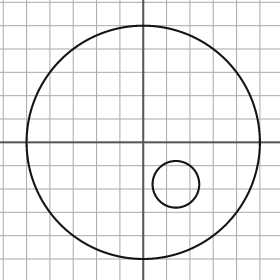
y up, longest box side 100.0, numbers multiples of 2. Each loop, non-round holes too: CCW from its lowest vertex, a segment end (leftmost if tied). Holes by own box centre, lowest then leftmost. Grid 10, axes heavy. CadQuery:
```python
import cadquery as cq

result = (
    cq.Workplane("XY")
    .moveTo(0.0, 0.0)
    .circle(50.0)
    .moveTo(14.0, -18.0)
    .circle(10.0)
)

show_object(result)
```